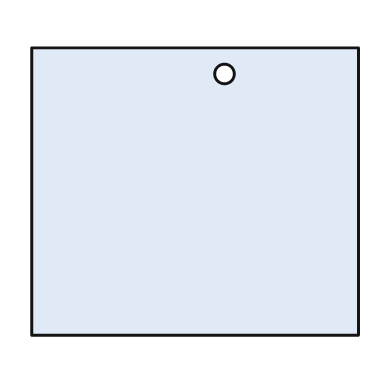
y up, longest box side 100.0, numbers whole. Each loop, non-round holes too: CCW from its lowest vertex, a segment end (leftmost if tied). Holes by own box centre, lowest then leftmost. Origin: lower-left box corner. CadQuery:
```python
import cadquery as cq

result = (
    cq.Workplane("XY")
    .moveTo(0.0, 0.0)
    .lineTo(100.0, 0.0)
    .lineTo(100.0, 88.0)
    .lineTo(0.0, 88.0)
    .close()
    .moveTo(59.0, 80.0)
    .circle(3.0)
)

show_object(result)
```